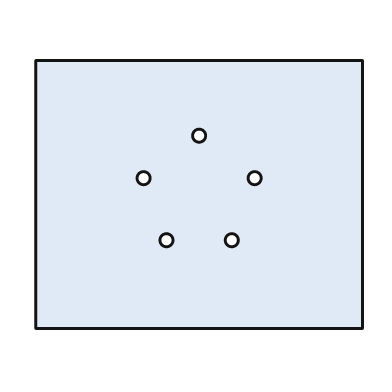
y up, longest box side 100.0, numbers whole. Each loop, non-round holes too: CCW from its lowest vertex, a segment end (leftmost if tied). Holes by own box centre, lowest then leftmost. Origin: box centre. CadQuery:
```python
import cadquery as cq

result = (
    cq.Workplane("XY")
    .moveTo(-50.0, -41.0)
    .lineTo(50.0, -41.0)
    .lineTo(50.0, 41.0)
    .lineTo(-50.0, 41.0)
    .close()
    .moveTo(-10.0, -14.0)
    .circle(2.0)
    .moveTo(10.0, -14.0)
    .circle(2.0)
    .moveTo(-17.0, 5.0)
    .circle(2.0)
    .moveTo(17.0, 5.0)
    .circle(2.0)
    .moveTo(0.0, 18.0)
    .circle(2.0)
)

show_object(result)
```